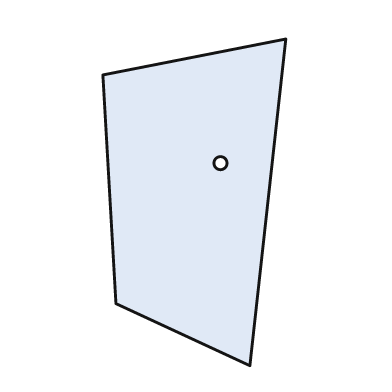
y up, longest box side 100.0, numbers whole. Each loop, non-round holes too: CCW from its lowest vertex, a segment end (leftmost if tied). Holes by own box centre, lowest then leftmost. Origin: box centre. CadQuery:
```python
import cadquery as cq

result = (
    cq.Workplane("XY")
    .moveTo(17.0, -50.0)
    .lineTo(28.0, 50.0)
    .lineTo(-28.0, 39.0)
    .lineTo(-24.0, -31.0)
    .close()
    .moveTo(8.0, 12.0)
    .circle(2.0)
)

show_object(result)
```